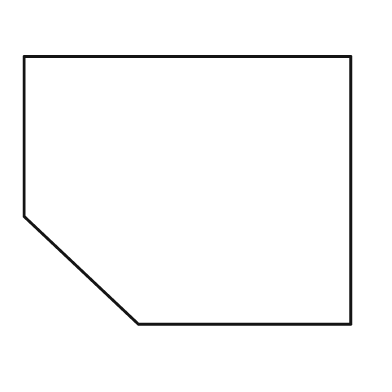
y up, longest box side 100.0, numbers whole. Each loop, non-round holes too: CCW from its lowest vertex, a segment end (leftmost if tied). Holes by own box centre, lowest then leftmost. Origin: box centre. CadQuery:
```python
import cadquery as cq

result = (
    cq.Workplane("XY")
    .moveTo(-15.0, -41.0)
    .lineTo(50.0, -41.0)
    .lineTo(50.0, 41.0)
    .lineTo(-50.0, 41.0)
    .lineTo(-50.0, -8.0)
    .close()
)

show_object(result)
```